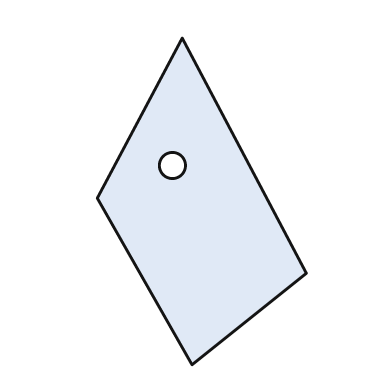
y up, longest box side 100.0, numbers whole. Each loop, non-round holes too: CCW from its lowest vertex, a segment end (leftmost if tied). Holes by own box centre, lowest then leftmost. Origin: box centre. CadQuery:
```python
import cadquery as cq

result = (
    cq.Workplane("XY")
    .moveTo(-3.0, -50.0)
    .lineTo(32.0, -22.0)
    .lineTo(-6.0, 50.0)
    .lineTo(-32.0, 1.0)
    .close()
    .moveTo(-9.0, 11.0)
    .circle(4.0)
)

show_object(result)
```